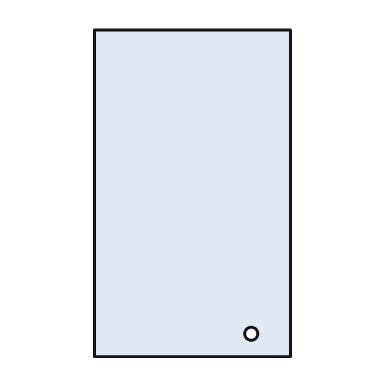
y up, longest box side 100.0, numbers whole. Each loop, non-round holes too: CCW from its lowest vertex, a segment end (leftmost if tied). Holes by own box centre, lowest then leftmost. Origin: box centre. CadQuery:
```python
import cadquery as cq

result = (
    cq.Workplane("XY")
    .moveTo(-30.0, -50.0)
    .lineTo(30.0, -50.0)
    .lineTo(30.0, 50.0)
    .lineTo(-30.0, 50.0)
    .close()
    .moveTo(18.0, -43.0)
    .circle(2.0)
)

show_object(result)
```